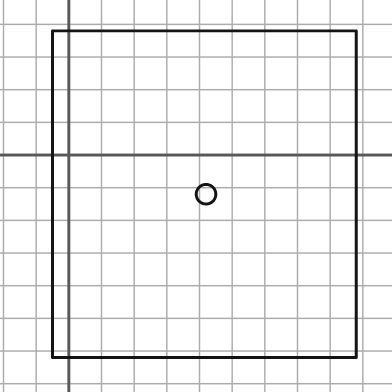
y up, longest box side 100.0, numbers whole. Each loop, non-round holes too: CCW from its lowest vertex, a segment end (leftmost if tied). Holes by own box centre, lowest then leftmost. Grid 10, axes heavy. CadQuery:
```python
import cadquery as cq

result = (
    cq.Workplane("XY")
    .moveTo(-5.0, -62.0)
    .lineTo(88.0, -62.0)
    .lineTo(88.0, 38.0)
    .lineTo(-5.0, 38.0)
    .close()
    .moveTo(42.0, -12.0)
    .circle(3.0)
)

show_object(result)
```